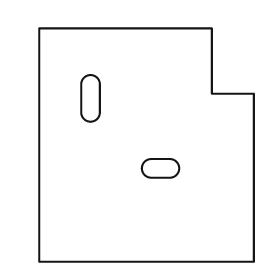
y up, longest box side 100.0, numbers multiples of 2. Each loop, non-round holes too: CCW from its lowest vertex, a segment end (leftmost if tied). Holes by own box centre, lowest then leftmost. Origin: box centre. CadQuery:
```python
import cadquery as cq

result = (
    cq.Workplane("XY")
    .moveTo(-46.0, -50.0)
    .lineTo(46.0, -50.0)
    .lineTo(46.0, 22.0)
    .lineTo(28.0, 22.0)
    .lineTo(28.0, 50.0)
    .lineTo(-46.0, 50.0)
    .close()
    .moveTo(2.0, -14.0)
    .lineTo(10.0, -14.0)
    .threePointArc((14.0, -10.0), (10.0, -6.0))
    .lineTo(2.0, -6.0)
    .threePointArc((-2.0, -10.0), (2.0, -14.0))
    .close()
    .moveTo(-28.0, 14.0)
    .threePointArc((-24.0, 10.0), (-20.0, 14.0))
    .lineTo(-20.0, 26.0)
    .threePointArc((-24.0, 30.0), (-28.0, 26.0))
    .close()
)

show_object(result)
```